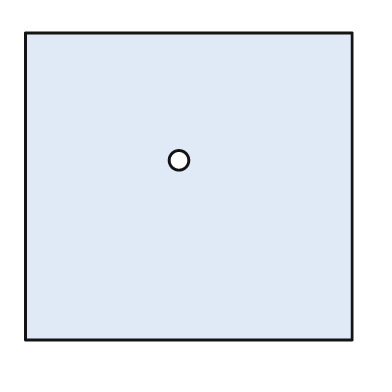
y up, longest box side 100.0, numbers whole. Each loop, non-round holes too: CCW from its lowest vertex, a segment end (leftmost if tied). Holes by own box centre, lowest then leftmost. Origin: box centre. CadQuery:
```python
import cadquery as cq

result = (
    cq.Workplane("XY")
    .moveTo(-50.0, -47.0)
    .lineTo(50.0, -47.0)
    .lineTo(50.0, 47.0)
    .lineTo(-50.0, 47.0)
    .close()
    .moveTo(-3.0, 8.0)
    .circle(3.0)
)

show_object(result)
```